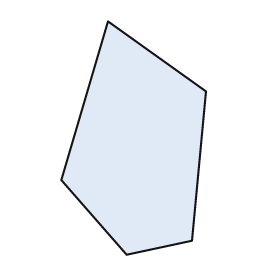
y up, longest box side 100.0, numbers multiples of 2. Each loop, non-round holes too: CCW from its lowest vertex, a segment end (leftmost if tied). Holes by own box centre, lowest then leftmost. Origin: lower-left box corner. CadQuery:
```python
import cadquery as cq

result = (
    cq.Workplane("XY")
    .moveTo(28.0, 0.0)
    .lineTo(56.0, 6.0)
    .lineTo(62.0, 70.0)
    .lineTo(20.0, 100.0)
    .lineTo(0.0, 32.0)
    .close()
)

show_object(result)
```